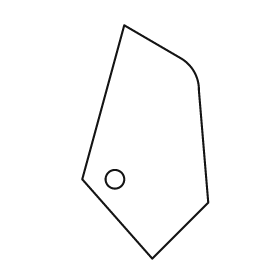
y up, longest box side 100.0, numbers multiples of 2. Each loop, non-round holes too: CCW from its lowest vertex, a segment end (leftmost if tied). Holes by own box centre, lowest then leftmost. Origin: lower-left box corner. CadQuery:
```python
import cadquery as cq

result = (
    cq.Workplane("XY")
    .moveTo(30.0, 0.0)
    .lineTo(54.0, 24.0)
    .lineTo(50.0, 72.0)
    .threePointArc((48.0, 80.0), (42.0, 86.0))
    .lineTo(18.0, 100.0)
    .lineTo(0.0, 34.0)
    .close()
    .moveTo(14.0, 34.0)
    .circle(4.0)
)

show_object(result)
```